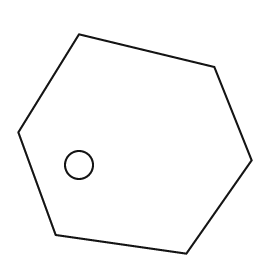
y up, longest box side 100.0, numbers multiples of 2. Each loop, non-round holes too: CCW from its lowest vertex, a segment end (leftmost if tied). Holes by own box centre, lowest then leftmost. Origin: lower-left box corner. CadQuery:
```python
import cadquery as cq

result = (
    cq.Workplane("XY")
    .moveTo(72.0, 0.0)
    .lineTo(100.0, 40.0)
    .lineTo(84.0, 80.0)
    .lineTo(26.0, 94.0)
    .lineTo(0.0, 52.0)
    .lineTo(16.0, 8.0)
    .close()
    .moveTo(26.0, 38.0)
    .circle(6.0)
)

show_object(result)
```